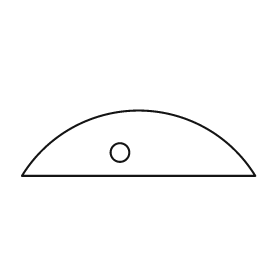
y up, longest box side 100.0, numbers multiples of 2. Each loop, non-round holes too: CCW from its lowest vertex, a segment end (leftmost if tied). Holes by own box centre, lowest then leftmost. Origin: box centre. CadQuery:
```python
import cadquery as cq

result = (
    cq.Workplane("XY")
    .moveTo(-50.0, -14.0)
    .lineTo(50.0, -14.0)
    .threePointArc((0.0, 14.0), (-50.0, -14.0))
    .close()
    .moveTo(-8.0, -4.0)
    .circle(4.0)
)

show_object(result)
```